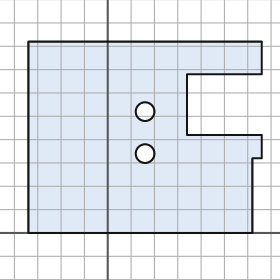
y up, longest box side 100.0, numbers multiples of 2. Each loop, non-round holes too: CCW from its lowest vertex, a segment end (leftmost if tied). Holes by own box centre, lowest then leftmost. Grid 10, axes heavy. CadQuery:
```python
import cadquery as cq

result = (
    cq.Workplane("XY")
    .moveTo(-34.0, 0.0)
    .lineTo(62.0, 0.0)
    .lineTo(62.0, 32.0)
    .lineTo(66.0, 32.0)
    .lineTo(66.0, 42.0)
    .lineTo(34.0, 42.0)
    .lineTo(34.0, 68.0)
    .lineTo(66.0, 68.0)
    .lineTo(66.0, 82.0)
    .lineTo(-34.0, 82.0)
    .close()
    .moveTo(16.0, 34.0)
    .circle(4.0)
    .moveTo(16.0, 52.0)
    .circle(4.0)
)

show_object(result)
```